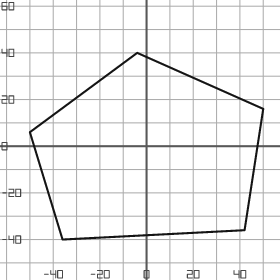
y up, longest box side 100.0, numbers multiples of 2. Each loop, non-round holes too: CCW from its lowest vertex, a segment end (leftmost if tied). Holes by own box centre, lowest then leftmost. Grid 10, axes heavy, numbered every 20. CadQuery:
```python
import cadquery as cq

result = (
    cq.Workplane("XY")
    .moveTo(-36.0, -40.0)
    .lineTo(42.0, -36.0)
    .lineTo(50.0, 16.0)
    .lineTo(-4.0, 40.0)
    .lineTo(-50.0, 6.0)
    .close()
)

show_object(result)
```